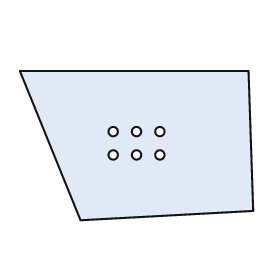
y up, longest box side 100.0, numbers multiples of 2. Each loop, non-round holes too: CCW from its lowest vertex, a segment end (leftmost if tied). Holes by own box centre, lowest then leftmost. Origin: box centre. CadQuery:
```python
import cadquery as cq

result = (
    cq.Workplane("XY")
    .moveTo(-24.0, -32.0)
    .lineTo(50.0, -28.0)
    .lineTo(48.0, 32.0)
    .lineTo(-50.0, 32.0)
    .close()
    .moveTo(-10.0, -4.0)
    .circle(2.0)
    .moveTo(0.0, -4.0)
    .circle(2.0)
    .moveTo(10.0, -4.0)
    .circle(2.0)
    .moveTo(-10.0, 6.0)
    .circle(2.0)
    .moveTo(0.0, 6.0)
    .circle(2.0)
    .moveTo(10.0, 6.0)
    .circle(2.0)
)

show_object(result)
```